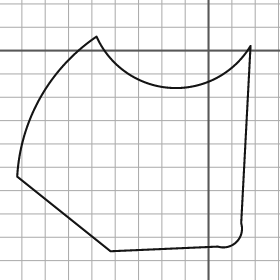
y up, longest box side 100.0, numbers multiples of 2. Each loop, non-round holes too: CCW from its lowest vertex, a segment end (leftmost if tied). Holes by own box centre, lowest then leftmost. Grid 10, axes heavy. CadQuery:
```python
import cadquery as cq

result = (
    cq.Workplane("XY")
    .moveTo(-42.0, -86.0)
    .lineTo(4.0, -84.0)
    .threePointArc((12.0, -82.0), (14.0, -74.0))
    .lineTo(18.0, 2.0)
    .threePointArc((-16.0, -16.0), (-48.0, 6.0))
    .threePointArc((-72.0, -20.0), (-82.0, -54.0))
    .close()
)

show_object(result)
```